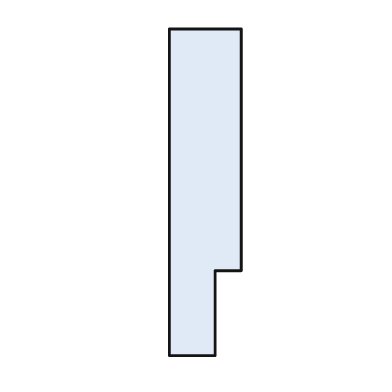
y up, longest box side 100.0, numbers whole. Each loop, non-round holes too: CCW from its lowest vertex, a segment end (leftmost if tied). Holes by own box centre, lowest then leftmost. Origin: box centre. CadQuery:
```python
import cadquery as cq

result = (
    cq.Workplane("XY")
    .moveTo(-11.0, -50.0)
    .lineTo(3.0, -50.0)
    .lineTo(3.0, -24.0)
    .lineTo(11.0, -24.0)
    .lineTo(11.0, 50.0)
    .lineTo(-11.0, 50.0)
    .close()
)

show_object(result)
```